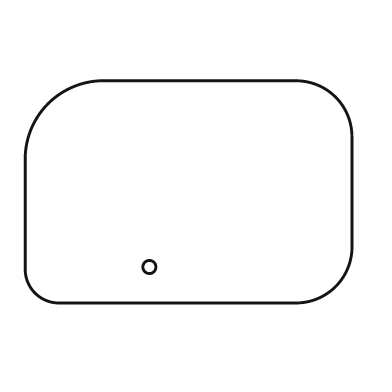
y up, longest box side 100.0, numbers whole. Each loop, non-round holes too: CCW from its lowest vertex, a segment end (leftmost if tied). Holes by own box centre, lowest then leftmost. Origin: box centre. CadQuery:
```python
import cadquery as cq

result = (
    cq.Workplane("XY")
    .moveTo(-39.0, -34.0)
    .lineTo(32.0, -34.0)
    .threePointArc((45.0, -29.0), (50.0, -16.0))
    .lineTo(50.0, 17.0)
    .threePointArc((45.0, 29.0), (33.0, 34.0))
    .lineTo(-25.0, 34.0)
    .threePointArc((-43.0, 27.0), (-50.0, 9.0))
    .lineTo(-50.0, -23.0)
    .threePointArc((-47.0, -31.0), (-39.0, -34.0))
    .close()
    .moveTo(-12.0, -23.0)
    .circle(2.0)
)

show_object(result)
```